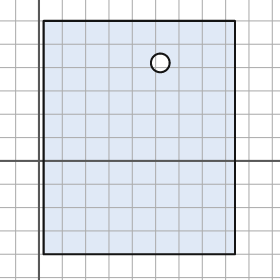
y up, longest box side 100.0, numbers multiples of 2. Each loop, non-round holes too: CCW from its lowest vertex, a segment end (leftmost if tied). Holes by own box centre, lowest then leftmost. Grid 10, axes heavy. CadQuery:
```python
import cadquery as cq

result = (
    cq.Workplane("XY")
    .moveTo(2.0, -40.0)
    .lineTo(84.0, -40.0)
    .lineTo(84.0, 60.0)
    .lineTo(2.0, 60.0)
    .close()
    .moveTo(52.0, 42.0)
    .circle(4.0)
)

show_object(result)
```